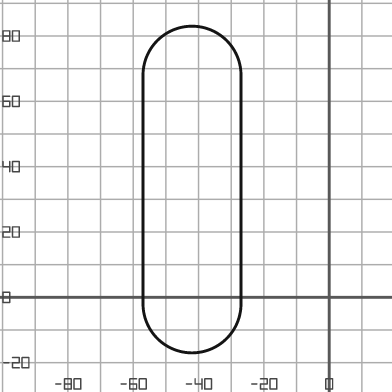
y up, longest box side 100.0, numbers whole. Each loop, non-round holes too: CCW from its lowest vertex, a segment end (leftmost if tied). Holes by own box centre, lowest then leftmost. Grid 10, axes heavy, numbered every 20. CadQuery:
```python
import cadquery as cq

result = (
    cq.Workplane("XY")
    .moveTo(-57.0, -2.0)
    .threePointArc((-42.0, -17.0), (-27.0, -2.0))
    .lineTo(-27.0, 68.0)
    .threePointArc((-42.0, 83.0), (-57.0, 68.0))
    .close()
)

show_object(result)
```